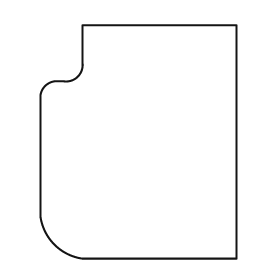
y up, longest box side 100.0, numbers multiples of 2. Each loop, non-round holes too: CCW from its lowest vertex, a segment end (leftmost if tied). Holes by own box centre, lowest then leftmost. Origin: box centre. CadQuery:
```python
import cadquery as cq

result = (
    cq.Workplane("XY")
    .moveTo(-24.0, -50.0)
    .lineTo(42.0, -50.0)
    .lineTo(42.0, 50.0)
    .lineTo(-24.0, 50.0)
    .lineTo(-24.0, 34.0)
    .threePointArc((-26.0, 28.0), (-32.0, 26.0))
    .lineTo(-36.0, 26.0)
    .threePointArc((-40.0, 24.0), (-42.0, 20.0))
    .lineTo(-42.0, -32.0)
    .threePointArc((-36.0, -44.0), (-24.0, -50.0))
    .close()
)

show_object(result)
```